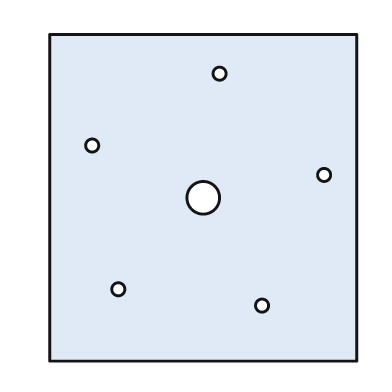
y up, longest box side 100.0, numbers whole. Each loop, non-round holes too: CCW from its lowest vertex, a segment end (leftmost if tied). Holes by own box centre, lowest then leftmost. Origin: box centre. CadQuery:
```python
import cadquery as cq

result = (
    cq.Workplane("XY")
    .moveTo(-47.0, -50.0)
    .lineTo(47.0, -50.0)
    .lineTo(47.0, 50.0)
    .lineTo(-47.0, 50.0)
    .close()
    .moveTo(18.0, -33.0)
    .circle(2.0)
    .moveTo(-26.0, -28.0)
    .circle(2.0)
    .moveTo(0.0, 0.0)
    .circle(5.0)
    .moveTo(37.0, 7.0)
    .circle(2.0)
    .moveTo(-34.0, 16.0)
    .circle(2.0)
    .moveTo(5.0, 38.0)
    .circle(2.0)
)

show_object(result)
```